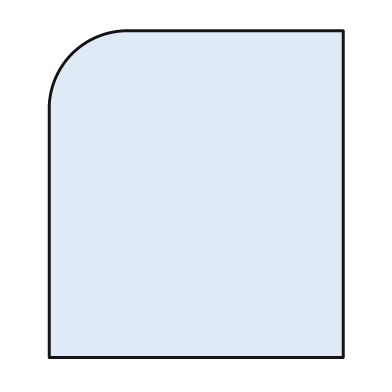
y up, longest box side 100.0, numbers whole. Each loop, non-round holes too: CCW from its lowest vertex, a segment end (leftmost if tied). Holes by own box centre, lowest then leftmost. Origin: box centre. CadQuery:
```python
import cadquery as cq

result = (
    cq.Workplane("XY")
    .moveTo(-45.0, -50.0)
    .lineTo(45.0, -50.0)
    .lineTo(45.0, 50.0)
    .lineTo(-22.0, 50.0)
    .threePointArc((-38.0, 43.0), (-45.0, 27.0))
    .close()
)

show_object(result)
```